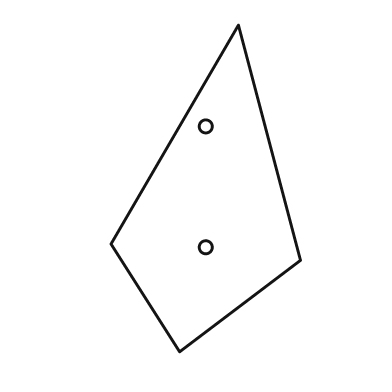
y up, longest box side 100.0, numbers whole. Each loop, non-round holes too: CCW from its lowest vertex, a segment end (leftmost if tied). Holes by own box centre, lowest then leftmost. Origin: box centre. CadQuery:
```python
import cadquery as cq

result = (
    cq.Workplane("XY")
    .moveTo(-8.0, -50.0)
    .lineTo(29.0, -22.0)
    .lineTo(10.0, 50.0)
    .lineTo(-29.0, -17.0)
    .close()
    .moveTo(0.0, -18.0)
    .circle(2.0)
    .moveTo(0.0, 19.0)
    .circle(2.0)
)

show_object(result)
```